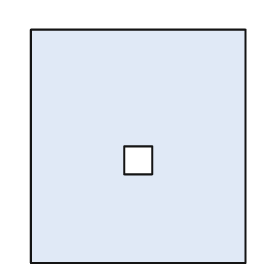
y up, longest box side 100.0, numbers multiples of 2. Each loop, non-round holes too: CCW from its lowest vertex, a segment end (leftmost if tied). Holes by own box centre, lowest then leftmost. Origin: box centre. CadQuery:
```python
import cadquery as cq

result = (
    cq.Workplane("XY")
    .moveTo(-46.0, -50.0)
    .lineTo(46.0, -50.0)
    .lineTo(46.0, 50.0)
    .lineTo(-46.0, 50.0)
    .close()
    .moveTo(-6.0, -12.0)
    .lineTo(6.0, -12.0)
    .lineTo(6.0, 0.0)
    .lineTo(-6.0, 0.0)
    .close()
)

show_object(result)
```